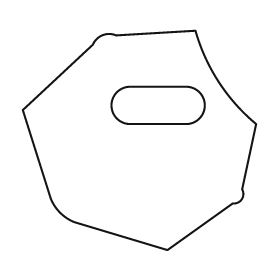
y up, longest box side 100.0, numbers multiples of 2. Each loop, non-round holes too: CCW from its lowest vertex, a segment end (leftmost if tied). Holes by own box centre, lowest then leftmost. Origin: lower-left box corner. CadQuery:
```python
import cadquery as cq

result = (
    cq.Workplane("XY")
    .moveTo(62.0, 0.0)
    .lineTo(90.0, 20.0)
    .threePointArc((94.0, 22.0), (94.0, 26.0))
    .lineTo(100.0, 54.0)
    .threePointArc((84.0, 72.0), (74.0, 94.0))
    .lineTo(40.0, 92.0)
    .threePointArc((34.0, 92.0), (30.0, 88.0))
    .lineTo(0.0, 60.0)
    .lineTo(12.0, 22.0)
    .threePointArc((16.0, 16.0), (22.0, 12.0))
    .close()
    .moveTo(46.0, 54.0)
    .lineTo(70.0, 54.0)
    .threePointArc((78.0, 62.0), (70.0, 70.0))
    .lineTo(46.0, 70.0)
    .threePointArc((38.0, 62.0), (46.0, 54.0))
    .close()
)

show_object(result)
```